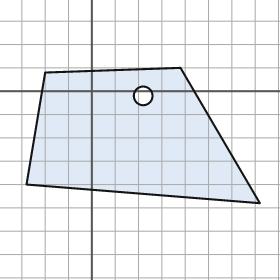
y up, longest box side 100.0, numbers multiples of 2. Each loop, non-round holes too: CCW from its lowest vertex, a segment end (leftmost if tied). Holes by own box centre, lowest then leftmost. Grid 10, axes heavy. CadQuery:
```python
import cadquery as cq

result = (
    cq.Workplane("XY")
    .moveTo(72.0, -48.0)
    .lineTo(38.0, 10.0)
    .lineTo(-20.0, 8.0)
    .lineTo(-28.0, -40.0)
    .close()
    .moveTo(22.0, -2.0)
    .circle(4.0)
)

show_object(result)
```